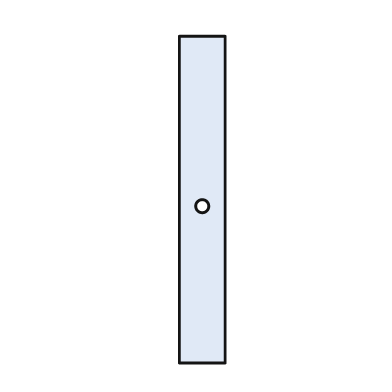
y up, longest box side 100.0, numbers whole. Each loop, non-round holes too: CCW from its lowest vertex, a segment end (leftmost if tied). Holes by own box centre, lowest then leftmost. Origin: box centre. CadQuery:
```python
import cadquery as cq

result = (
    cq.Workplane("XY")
    .moveTo(-7.0, -50.0)
    .lineTo(7.0, -50.0)
    .lineTo(7.0, 50.0)
    .lineTo(-7.0, 50.0)
    .close()
    .moveTo(0.0, -2.0)
    .circle(2.0)
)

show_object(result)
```